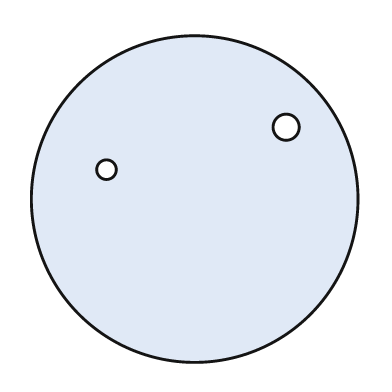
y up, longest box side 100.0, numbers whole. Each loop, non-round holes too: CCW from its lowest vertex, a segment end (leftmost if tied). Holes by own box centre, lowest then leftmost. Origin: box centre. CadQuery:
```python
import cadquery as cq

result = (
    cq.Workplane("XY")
    .moveTo(0.0, 0.0)
    .circle(50.0)
    .moveTo(-27.0, 9.0)
    .circle(3.0)
    .moveTo(28.0, 22.0)
    .circle(4.0)
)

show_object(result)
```